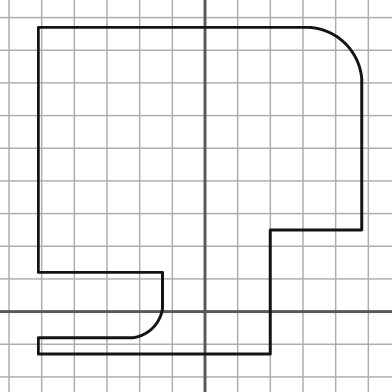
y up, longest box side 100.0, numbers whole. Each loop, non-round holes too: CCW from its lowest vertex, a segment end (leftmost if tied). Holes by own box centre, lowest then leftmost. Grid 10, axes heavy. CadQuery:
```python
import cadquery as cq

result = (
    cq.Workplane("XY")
    .moveTo(-51.0, -13.0)
    .lineTo(20.0, -13.0)
    .lineTo(20.0, 25.0)
    .lineTo(48.0, 25.0)
    .lineTo(48.0, 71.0)
    .threePointArc((43.0, 82.0), (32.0, 87.0))
    .lineTo(-51.0, 87.0)
    .lineTo(-51.0, 12.0)
    .lineTo(-13.0, 12.0)
    .lineTo(-13.0, 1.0)
    .threePointArc((-16.0, -5.0), (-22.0, -8.0))
    .lineTo(-51.0, -8.0)
    .close()
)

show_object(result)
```